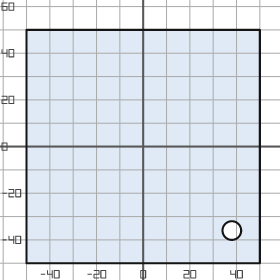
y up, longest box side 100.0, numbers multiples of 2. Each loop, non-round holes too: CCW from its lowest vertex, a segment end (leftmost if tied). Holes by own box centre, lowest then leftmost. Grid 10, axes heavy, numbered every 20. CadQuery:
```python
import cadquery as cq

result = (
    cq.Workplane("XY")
    .moveTo(-50.0, -50.0)
    .lineTo(50.0, -50.0)
    .lineTo(50.0, 50.0)
    .lineTo(-50.0, 50.0)
    .close()
    .moveTo(38.0, -36.0)
    .circle(4.0)
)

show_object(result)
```